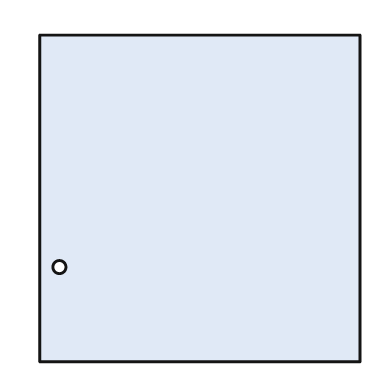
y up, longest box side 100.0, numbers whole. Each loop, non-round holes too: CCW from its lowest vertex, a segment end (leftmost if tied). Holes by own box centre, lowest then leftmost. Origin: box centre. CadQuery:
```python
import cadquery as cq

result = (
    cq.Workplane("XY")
    .moveTo(-49.0, -50.0)
    .lineTo(49.0, -50.0)
    .lineTo(49.0, 50.0)
    .lineTo(-49.0, 50.0)
    .close()
    .moveTo(-43.0, -21.0)
    .circle(2.0)
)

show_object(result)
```